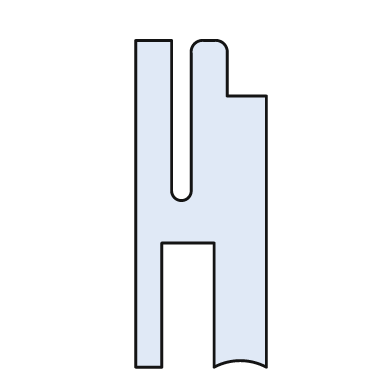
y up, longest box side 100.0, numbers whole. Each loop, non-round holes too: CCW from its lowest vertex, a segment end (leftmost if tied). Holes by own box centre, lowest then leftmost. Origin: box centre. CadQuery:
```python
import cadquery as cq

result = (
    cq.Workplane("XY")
    .moveTo(-20.0, -50.0)
    .lineTo(-12.0, -50.0)
    .lineTo(-12.0, -12.0)
    .lineTo(4.0, -12.0)
    .lineTo(4.0, -50.0)
    .threePointArc((12.0, -48.0), (20.0, -50.0))
    .lineTo(20.0, 33.0)
    .lineTo(8.0, 33.0)
    .lineTo(8.0, 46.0)
    .threePointArc((7.0, 49.0), (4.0, 50.0))
    .lineTo(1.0, 50.0)
    .threePointArc((-2.0, 49.0), (-3.0, 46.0))
    .lineTo(-3.0, 4.0)
    .threePointArc((-6.0, 1.0), (-9.0, 4.0))
    .lineTo(-9.0, 50.0)
    .lineTo(-20.0, 50.0)
    .close()
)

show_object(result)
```